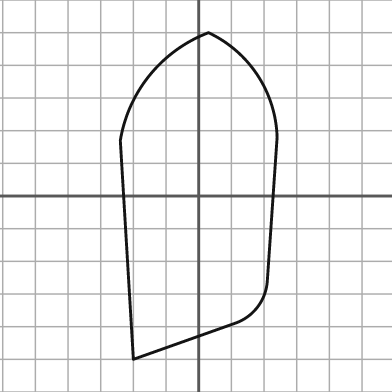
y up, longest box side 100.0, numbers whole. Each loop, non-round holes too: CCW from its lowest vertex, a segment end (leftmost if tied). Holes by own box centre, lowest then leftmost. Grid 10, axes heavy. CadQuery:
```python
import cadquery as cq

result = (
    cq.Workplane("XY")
    .moveTo(-20.0, -50.0)
    .lineTo(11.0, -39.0)
    .threePointArc((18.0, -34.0), (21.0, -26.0))
    .lineTo(24.0, 18.0)
    .threePointArc((18.0, 37.0), (3.0, 50.0))
    .threePointArc((-15.0, 37.0), (-24.0, 17.0))
    .close()
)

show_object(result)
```